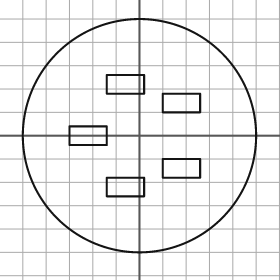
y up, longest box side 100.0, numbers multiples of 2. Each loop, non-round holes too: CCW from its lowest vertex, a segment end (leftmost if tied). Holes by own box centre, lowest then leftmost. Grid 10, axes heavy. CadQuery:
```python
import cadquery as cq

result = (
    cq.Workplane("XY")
    .moveTo(0.0, 0.0)
    .circle(50.0)
    .moveTo(-14.0, -26.0)
    .lineTo(2.0, -26.0)
    .lineTo(2.0, -18.0)
    .lineTo(-14.0, -18.0)
    .close()
    .moveTo(10.0, -18.0)
    .lineTo(26.0, -18.0)
    .lineTo(26.0, -10.0)
    .lineTo(10.0, -10.0)
    .close()
    .moveTo(-30.0, -4.0)
    .lineTo(-14.0, -4.0)
    .lineTo(-14.0, 4.0)
    .lineTo(-30.0, 4.0)
    .close()
    .moveTo(10.0, 10.0)
    .lineTo(26.0, 10.0)
    .lineTo(26.0, 18.0)
    .lineTo(10.0, 18.0)
    .close()
    .moveTo(-14.0, 18.0)
    .lineTo(2.0, 18.0)
    .lineTo(2.0, 26.0)
    .lineTo(-14.0, 26.0)
    .close()
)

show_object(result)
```